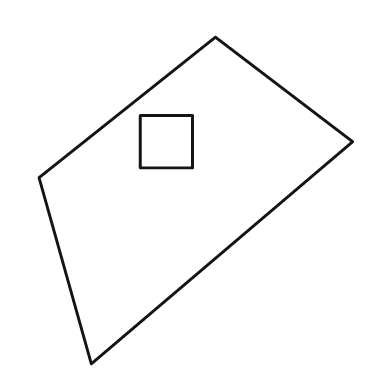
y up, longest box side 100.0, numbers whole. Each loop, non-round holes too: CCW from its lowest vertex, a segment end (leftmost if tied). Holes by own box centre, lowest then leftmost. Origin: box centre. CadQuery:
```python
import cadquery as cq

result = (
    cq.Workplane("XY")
    .moveTo(-32.0, -50.0)
    .lineTo(48.0, 18.0)
    .lineTo(6.0, 50.0)
    .lineTo(-48.0, 7.0)
    .close()
    .moveTo(-17.0, 10.0)
    .lineTo(-1.0, 10.0)
    .lineTo(-1.0, 26.0)
    .lineTo(-17.0, 26.0)
    .close()
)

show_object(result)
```